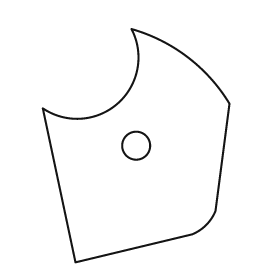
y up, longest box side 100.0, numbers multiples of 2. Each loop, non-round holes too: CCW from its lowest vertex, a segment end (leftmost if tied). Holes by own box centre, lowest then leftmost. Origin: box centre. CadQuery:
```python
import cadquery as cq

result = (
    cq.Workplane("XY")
    .moveTo(-26.0, -50.0)
    .lineTo(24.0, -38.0)
    .threePointArc((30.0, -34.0), (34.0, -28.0))
    .lineTo(40.0, 18.0)
    .threePointArc((22.0, 38.0), (-2.0, 50.0))
    .threePointArc((-8.0, 18.0), (-40.0, 16.0))
    .close()
    .moveTo(0.0, 0.0)
    .circle(6.0)
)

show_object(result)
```